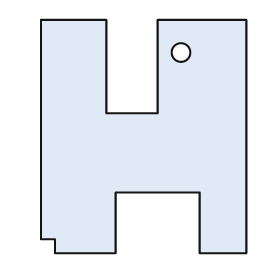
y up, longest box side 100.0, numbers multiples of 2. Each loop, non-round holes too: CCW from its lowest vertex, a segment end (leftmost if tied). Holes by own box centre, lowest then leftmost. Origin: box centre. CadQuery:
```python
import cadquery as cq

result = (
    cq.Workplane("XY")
    .moveTo(-38.0, -50.0)
    .lineTo(-12.0, -50.0)
    .lineTo(-12.0, -24.0)
    .lineTo(24.0, -24.0)
    .lineTo(24.0, -50.0)
    .lineTo(44.0, -50.0)
    .lineTo(44.0, 50.0)
    .lineTo(6.0, 50.0)
    .lineTo(6.0, 10.0)
    .lineTo(-16.0, 10.0)
    .lineTo(-16.0, 50.0)
    .lineTo(-44.0, 50.0)
    .lineTo(-44.0, -44.0)
    .lineTo(-38.0, -44.0)
    .close()
    .moveTo(16.0, 36.0)
    .circle(4.0)
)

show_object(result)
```